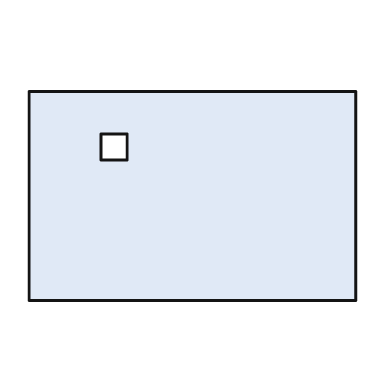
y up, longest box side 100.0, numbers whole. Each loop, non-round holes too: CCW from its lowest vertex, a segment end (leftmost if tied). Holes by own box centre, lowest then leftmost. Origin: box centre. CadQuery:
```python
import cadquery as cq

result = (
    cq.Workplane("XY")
    .moveTo(-50.0, -32.0)
    .lineTo(50.0, -32.0)
    .lineTo(50.0, 32.0)
    .lineTo(-50.0, 32.0)
    .close()
    .moveTo(-28.0, 11.0)
    .lineTo(-20.0, 11.0)
    .lineTo(-20.0, 19.0)
    .lineTo(-28.0, 19.0)
    .close()
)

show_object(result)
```